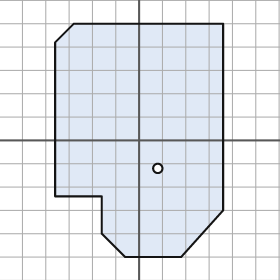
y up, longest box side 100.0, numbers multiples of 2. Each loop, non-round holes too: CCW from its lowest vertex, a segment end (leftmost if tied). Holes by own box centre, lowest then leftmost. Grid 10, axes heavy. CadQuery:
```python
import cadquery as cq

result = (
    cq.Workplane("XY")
    .moveTo(-6.0, -50.0)
    .lineTo(18.0, -50.0)
    .lineTo(36.0, -30.0)
    .lineTo(36.0, 50.0)
    .lineTo(-28.0, 50.0)
    .lineTo(-36.0, 42.0)
    .lineTo(-36.0, -24.0)
    .lineTo(-16.0, -24.0)
    .lineTo(-16.0, -40.0)
    .close()
    .moveTo(8.0, -12.0)
    .circle(2.0)
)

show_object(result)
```